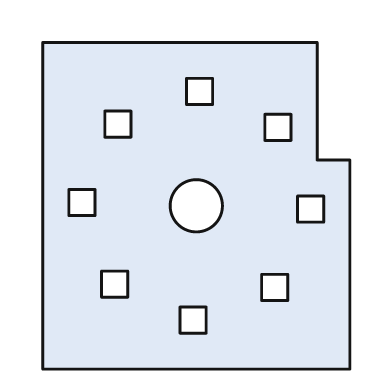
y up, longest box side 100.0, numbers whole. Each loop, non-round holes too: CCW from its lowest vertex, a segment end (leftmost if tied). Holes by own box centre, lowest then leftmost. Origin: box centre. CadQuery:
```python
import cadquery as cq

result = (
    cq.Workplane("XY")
    .moveTo(-47.0, -50.0)
    .lineTo(47.0, -50.0)
    .lineTo(47.0, 14.0)
    .lineTo(37.0, 14.0)
    .lineTo(37.0, 50.0)
    .lineTo(-47.0, 50.0)
    .close()
    .moveTo(-5.0, -39.0)
    .lineTo(3.0, -39.0)
    .lineTo(3.0, -31.0)
    .lineTo(-5.0, -31.0)
    .close()
    .moveTo(20.0, -29.0)
    .lineTo(28.0, -29.0)
    .lineTo(28.0, -21.0)
    .lineTo(20.0, -21.0)
    .close()
    .moveTo(-29.0, -28.0)
    .lineTo(-21.0, -28.0)
    .lineTo(-21.0, -20.0)
    .lineTo(-29.0, -20.0)
    .close()
    .moveTo(31.0, -5.0)
    .lineTo(39.0, -5.0)
    .lineTo(39.0, 3.0)
    .lineTo(31.0, 3.0)
    .close()
    .moveTo(0.0, 0.0)
    .circle(8.0)
    .moveTo(-39.0, -3.0)
    .lineTo(-31.0, -3.0)
    .lineTo(-31.0, 5.0)
    .lineTo(-39.0, 5.0)
    .close()
    .moveTo(21.0, 20.0)
    .lineTo(29.0, 20.0)
    .lineTo(29.0, 28.0)
    .lineTo(21.0, 28.0)
    .close()
    .moveTo(-28.0, 21.0)
    .lineTo(-20.0, 21.0)
    .lineTo(-20.0, 29.0)
    .lineTo(-28.0, 29.0)
    .close()
    .moveTo(-3.0, 31.0)
    .lineTo(5.0, 31.0)
    .lineTo(5.0, 39.0)
    .lineTo(-3.0, 39.0)
    .close()
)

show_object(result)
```